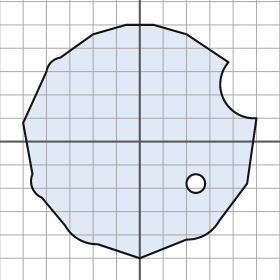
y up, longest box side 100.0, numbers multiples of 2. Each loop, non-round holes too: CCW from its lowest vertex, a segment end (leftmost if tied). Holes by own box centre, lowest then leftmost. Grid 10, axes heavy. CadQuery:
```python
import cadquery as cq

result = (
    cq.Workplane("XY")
    .moveTo(0.0, -50.0)
    .lineTo(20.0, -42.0)
    .threePointArc((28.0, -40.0), (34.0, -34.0))
    .lineTo(46.0, -18.0)
    .lineTo(50.0, 10.0)
    .threePointArc((36.0, 18.0), (38.0, 34.0))
    .lineTo(20.0, 46.0)
    .lineTo(6.0, 50.0)
    .lineTo(-6.0, 50.0)
    .lineTo(-20.0, 46.0)
    .lineTo(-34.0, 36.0)
    .threePointArc((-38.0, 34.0), (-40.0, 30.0))
    .lineTo(-50.0, 8.0)
    .lineTo(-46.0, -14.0)
    .threePointArc((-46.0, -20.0), (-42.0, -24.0))
    .lineTo(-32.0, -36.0)
    .threePointArc((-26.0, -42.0), (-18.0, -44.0))
    .close()
    .moveTo(24.0, -18.0)
    .circle(4.0)
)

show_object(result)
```